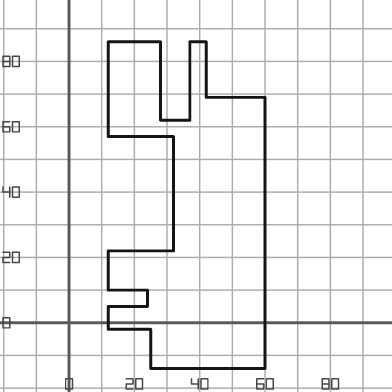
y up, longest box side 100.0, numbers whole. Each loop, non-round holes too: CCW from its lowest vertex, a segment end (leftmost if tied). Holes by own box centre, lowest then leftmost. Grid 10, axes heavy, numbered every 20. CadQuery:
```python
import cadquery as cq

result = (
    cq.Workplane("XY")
    .moveTo(25.0, -14.0)
    .lineTo(60.0, -14.0)
    .lineTo(60.0, 69.0)
    .lineTo(42.0, 69.0)
    .lineTo(42.0, 86.0)
    .lineTo(37.0, 86.0)
    .lineTo(37.0, 62.0)
    .lineTo(28.0, 62.0)
    .lineTo(28.0, 86.0)
    .lineTo(12.0, 86.0)
    .lineTo(12.0, 57.0)
    .lineTo(32.0, 57.0)
    .lineTo(32.0, 22.0)
    .lineTo(12.0, 22.0)
    .lineTo(12.0, 10.0)
    .lineTo(24.0, 10.0)
    .lineTo(24.0, 5.0)
    .lineTo(12.0, 5.0)
    .lineTo(12.0, -2.0)
    .lineTo(25.0, -2.0)
    .close()
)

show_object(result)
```